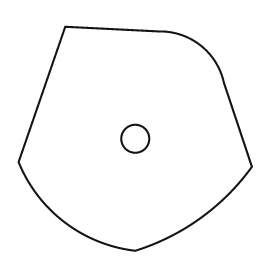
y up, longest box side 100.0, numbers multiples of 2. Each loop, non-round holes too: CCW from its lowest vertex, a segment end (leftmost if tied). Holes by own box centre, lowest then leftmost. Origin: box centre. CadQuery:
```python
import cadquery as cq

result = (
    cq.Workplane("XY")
    .moveTo(0.0, -48.0)
    .threePointArc((28.0, -34.0), (50.0, -12.0))
    .lineTo(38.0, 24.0)
    .threePointArc((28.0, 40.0), (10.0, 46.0))
    .lineTo(-30.0, 48.0)
    .lineTo(-50.0, -10.0)
    .threePointArc((-30.0, -36.0), (0.0, -48.0))
    .close()
    .moveTo(0.0, 0.0)
    .circle(6.0)
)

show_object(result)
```